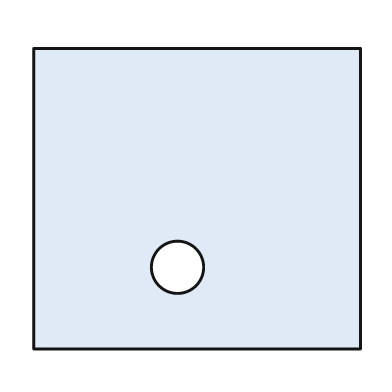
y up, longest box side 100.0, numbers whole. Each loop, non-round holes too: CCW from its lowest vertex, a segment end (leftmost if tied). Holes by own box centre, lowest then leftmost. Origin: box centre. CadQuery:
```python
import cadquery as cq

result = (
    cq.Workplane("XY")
    .moveTo(-50.0, -46.0)
    .lineTo(50.0, -46.0)
    .lineTo(50.0, 46.0)
    .lineTo(-50.0, 46.0)
    .close()
    .moveTo(-6.0, -21.0)
    .circle(8.0)
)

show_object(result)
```